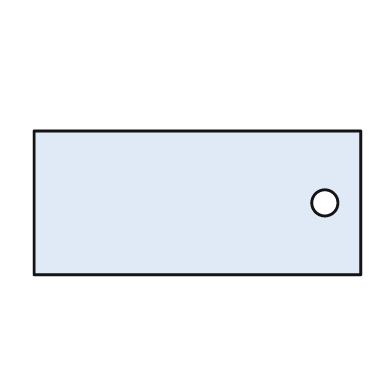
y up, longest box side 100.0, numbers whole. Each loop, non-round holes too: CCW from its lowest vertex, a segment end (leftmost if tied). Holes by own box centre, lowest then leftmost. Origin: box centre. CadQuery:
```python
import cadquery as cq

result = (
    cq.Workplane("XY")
    .moveTo(-50.0, -22.0)
    .lineTo(50.0, -22.0)
    .lineTo(50.0, 22.0)
    .lineTo(-50.0, 22.0)
    .close()
    .moveTo(39.0, 0.0)
    .circle(4.0)
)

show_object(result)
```